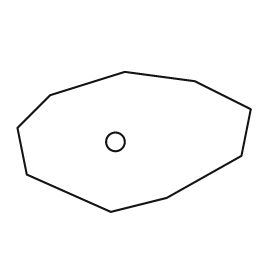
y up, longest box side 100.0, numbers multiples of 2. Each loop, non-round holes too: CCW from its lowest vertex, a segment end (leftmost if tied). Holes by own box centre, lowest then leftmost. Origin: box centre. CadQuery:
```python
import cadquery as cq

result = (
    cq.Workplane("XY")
    .moveTo(-10.0, -30.0)
    .lineTo(14.0, -24.0)
    .lineTo(46.0, -6.0)
    .lineTo(50.0, 14.0)
    .lineTo(26.0, 26.0)
    .lineTo(-4.0, 30.0)
    .lineTo(-36.0, 20.0)
    .lineTo(-50.0, 6.0)
    .lineTo(-46.0, -14.0)
    .close()
    .moveTo(-8.0, 0.0)
    .circle(4.0)
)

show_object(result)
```